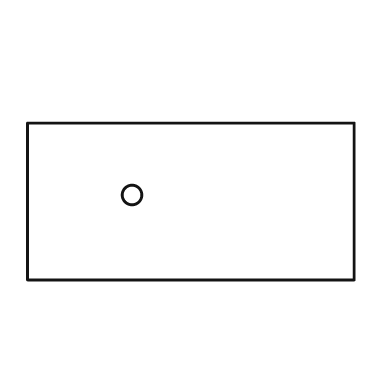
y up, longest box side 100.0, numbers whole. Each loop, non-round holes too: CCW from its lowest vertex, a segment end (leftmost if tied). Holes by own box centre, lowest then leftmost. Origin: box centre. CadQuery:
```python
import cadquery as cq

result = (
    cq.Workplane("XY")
    .moveTo(-50.0, -24.0)
    .lineTo(50.0, -24.0)
    .lineTo(50.0, 24.0)
    .lineTo(-50.0, 24.0)
    .close()
    .moveTo(-18.0, 2.0)
    .circle(3.0)
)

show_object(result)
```